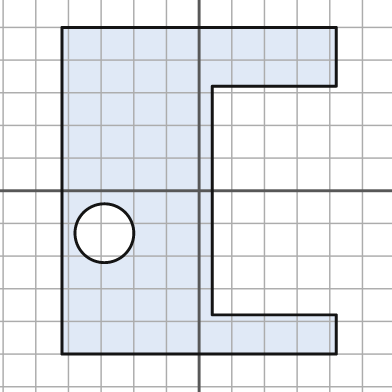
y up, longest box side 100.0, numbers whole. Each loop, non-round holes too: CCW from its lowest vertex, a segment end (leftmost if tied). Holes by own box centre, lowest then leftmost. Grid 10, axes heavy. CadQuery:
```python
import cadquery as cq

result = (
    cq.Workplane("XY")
    .moveTo(-42.0, -50.0)
    .lineTo(42.0, -50.0)
    .lineTo(42.0, -38.0)
    .lineTo(4.0, -38.0)
    .lineTo(4.0, 32.0)
    .lineTo(42.0, 32.0)
    .lineTo(42.0, 50.0)
    .lineTo(-42.0, 50.0)
    .close()
    .moveTo(-29.0, -13.0)
    .circle(9.0)
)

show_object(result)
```